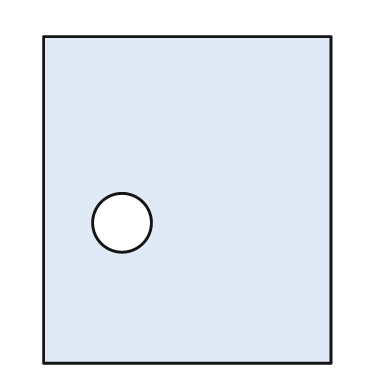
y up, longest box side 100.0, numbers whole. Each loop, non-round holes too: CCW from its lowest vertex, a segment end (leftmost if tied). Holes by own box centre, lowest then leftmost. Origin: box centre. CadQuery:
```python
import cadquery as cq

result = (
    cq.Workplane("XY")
    .moveTo(-44.0, -50.0)
    .lineTo(44.0, -50.0)
    .lineTo(44.0, 50.0)
    .lineTo(-44.0, 50.0)
    .close()
    .moveTo(-20.0, -7.0)
    .circle(9.0)
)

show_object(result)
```